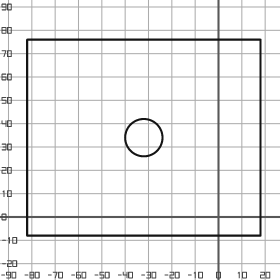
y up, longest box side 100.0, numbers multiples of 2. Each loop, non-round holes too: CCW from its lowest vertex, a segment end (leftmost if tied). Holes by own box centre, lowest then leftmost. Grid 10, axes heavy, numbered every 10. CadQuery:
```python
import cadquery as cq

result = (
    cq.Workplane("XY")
    .moveTo(-82.0, -8.0)
    .lineTo(18.0, -8.0)
    .lineTo(18.0, 76.0)
    .lineTo(-82.0, 76.0)
    .close()
    .moveTo(-32.0, 34.0)
    .circle(8.0)
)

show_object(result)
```